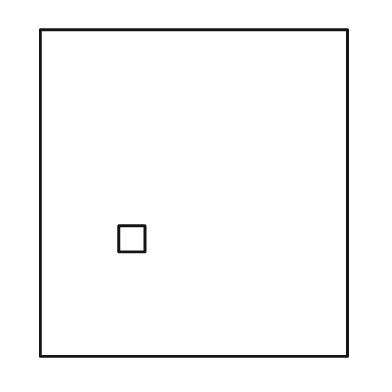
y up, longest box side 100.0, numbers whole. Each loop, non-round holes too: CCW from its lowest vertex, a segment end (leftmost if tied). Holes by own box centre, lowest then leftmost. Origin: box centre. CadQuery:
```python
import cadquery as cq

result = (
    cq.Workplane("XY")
    .moveTo(-47.0, -50.0)
    .lineTo(47.0, -50.0)
    .lineTo(47.0, 50.0)
    .lineTo(-47.0, 50.0)
    .close()
    .moveTo(-23.0, -18.0)
    .lineTo(-15.0, -18.0)
    .lineTo(-15.0, -10.0)
    .lineTo(-23.0, -10.0)
    .close()
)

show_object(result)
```